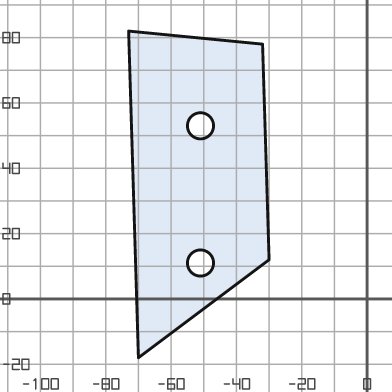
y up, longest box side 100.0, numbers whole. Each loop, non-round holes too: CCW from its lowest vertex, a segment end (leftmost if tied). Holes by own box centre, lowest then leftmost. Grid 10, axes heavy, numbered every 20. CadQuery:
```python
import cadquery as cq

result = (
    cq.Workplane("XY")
    .moveTo(-70.0, -18.0)
    .lineTo(-30.0, 12.0)
    .lineTo(-32.0, 78.0)
    .lineTo(-73.0, 82.0)
    .close()
    .moveTo(-51.0, 11.0)
    .circle(4.0)
    .moveTo(-51.0, 53.0)
    .circle(4.0)
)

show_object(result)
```